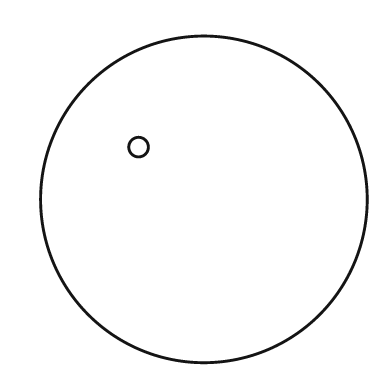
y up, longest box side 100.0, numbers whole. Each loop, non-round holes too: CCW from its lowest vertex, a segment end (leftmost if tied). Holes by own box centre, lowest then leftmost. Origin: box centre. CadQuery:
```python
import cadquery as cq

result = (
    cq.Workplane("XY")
    .moveTo(0.0, 0.0)
    .circle(50.0)
    .moveTo(-20.0, 16.0)
    .circle(3.0)
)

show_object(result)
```